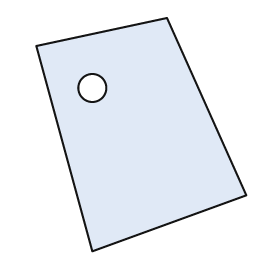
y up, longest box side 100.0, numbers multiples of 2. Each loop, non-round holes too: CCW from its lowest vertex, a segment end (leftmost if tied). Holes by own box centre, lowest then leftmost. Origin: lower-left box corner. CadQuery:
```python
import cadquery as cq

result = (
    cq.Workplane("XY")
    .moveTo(24.0, 0.0)
    .lineTo(90.0, 24.0)
    .lineTo(56.0, 100.0)
    .lineTo(0.0, 88.0)
    .close()
    .moveTo(24.0, 70.0)
    .circle(6.0)
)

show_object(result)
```